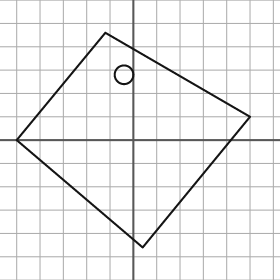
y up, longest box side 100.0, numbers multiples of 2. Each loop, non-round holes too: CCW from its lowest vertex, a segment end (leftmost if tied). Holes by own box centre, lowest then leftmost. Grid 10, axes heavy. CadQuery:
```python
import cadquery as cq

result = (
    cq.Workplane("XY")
    .moveTo(4.0, -46.0)
    .lineTo(50.0, 10.0)
    .lineTo(-12.0, 46.0)
    .lineTo(-50.0, 0.0)
    .close()
    .moveTo(-4.0, 28.0)
    .circle(4.0)
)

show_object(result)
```